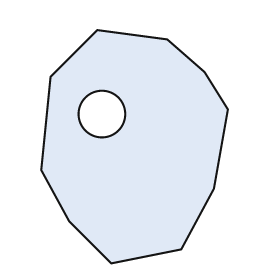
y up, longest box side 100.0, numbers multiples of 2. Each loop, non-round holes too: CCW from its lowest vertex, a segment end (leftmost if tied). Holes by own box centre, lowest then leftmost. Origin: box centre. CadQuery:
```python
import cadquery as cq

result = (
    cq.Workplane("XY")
    .moveTo(-10.0, -50.0)
    .lineTo(20.0, -44.0)
    .lineTo(34.0, -18.0)
    .lineTo(40.0, 16.0)
    .lineTo(30.0, 32.0)
    .lineTo(14.0, 46.0)
    .lineTo(-16.0, 50.0)
    .lineTo(-36.0, 30.0)
    .lineTo(-40.0, -10.0)
    .lineTo(-28.0, -32.0)
    .close()
    .moveTo(-14.0, 14.0)
    .circle(10.0)
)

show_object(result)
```